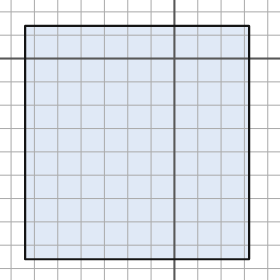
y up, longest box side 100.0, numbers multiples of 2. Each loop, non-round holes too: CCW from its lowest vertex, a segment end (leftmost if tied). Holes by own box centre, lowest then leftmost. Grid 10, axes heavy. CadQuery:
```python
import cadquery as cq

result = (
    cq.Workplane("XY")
    .moveTo(-64.0, -86.0)
    .lineTo(32.0, -86.0)
    .lineTo(32.0, 14.0)
    .lineTo(-64.0, 14.0)
    .close()
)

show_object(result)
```